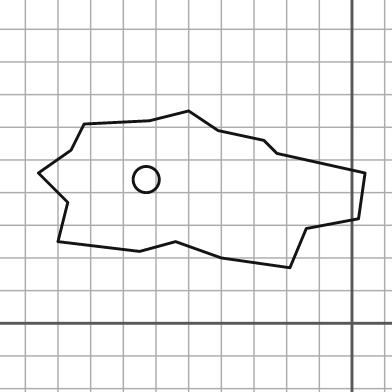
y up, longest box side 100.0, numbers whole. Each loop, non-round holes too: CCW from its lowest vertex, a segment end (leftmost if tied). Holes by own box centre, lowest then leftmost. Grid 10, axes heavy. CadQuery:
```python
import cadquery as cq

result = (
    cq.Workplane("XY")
    .moveTo(-19.0, 17.0)
    .lineTo(-14.0, 29.0)
    .lineTo(2.0, 32.0)
    .lineTo(4.0, 46.0)
    .lineTo(-23.0, 52.0)
    .lineTo(-27.0, 56.0)
    .lineTo(-41.0, 59.0)
    .lineTo(-50.0, 65.0)
    .lineTo(-62.0, 62.0)
    .lineTo(-82.0, 61.0)
    .lineTo(-86.0, 53.0)
    .lineTo(-96.0, 46.0)
    .lineTo(-87.0, 37.0)
    .lineTo(-90.0, 25.0)
    .lineTo(-65.0, 22.0)
    .lineTo(-54.0, 25.0)
    .lineTo(-40.0, 20.0)
    .close()
    .moveTo(-63.0, 44.0)
    .circle(4.0)
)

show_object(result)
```